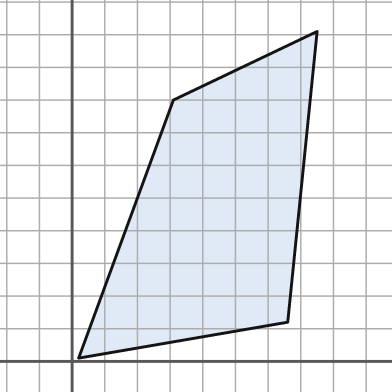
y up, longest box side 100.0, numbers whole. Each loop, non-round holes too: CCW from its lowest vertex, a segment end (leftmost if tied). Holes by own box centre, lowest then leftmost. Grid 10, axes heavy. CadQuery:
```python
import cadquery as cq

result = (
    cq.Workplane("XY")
    .moveTo(2.0, 1.0)
    .lineTo(66.0, 12.0)
    .lineTo(75.0, 101.0)
    .lineTo(31.0, 80.0)
    .close()
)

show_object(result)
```